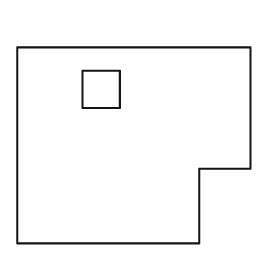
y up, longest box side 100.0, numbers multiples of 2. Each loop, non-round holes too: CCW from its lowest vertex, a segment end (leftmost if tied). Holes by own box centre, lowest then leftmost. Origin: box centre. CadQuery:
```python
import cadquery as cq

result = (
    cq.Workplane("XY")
    .moveTo(-50.0, -42.0)
    .lineTo(28.0, -42.0)
    .lineTo(28.0, -10.0)
    .lineTo(50.0, -10.0)
    .lineTo(50.0, 42.0)
    .lineTo(-50.0, 42.0)
    .close()
    .moveTo(-22.0, 16.0)
    .lineTo(-6.0, 16.0)
    .lineTo(-6.0, 32.0)
    .lineTo(-22.0, 32.0)
    .close()
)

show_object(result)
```